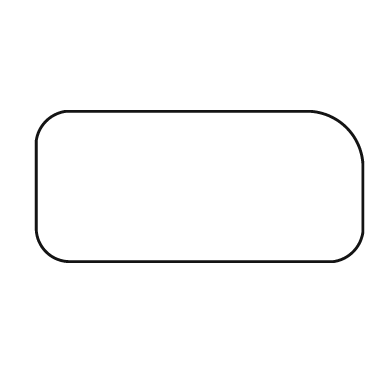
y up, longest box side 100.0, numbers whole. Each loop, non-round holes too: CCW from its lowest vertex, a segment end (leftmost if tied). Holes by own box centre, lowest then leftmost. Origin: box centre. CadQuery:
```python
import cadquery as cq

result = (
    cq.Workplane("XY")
    .moveTo(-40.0, -23.0)
    .lineTo(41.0, -23.0)
    .threePointArc((47.0, -20.0), (50.0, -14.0))
    .lineTo(50.0, 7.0)
    .threePointArc((45.0, 18.0), (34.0, 23.0))
    .lineTo(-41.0, 23.0)
    .threePointArc((-47.0, 20.0), (-50.0, 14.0))
    .lineTo(-50.0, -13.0)
    .threePointArc((-47.0, -20.0), (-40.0, -23.0))
    .close()
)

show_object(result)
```